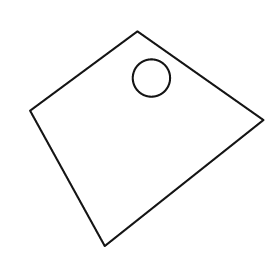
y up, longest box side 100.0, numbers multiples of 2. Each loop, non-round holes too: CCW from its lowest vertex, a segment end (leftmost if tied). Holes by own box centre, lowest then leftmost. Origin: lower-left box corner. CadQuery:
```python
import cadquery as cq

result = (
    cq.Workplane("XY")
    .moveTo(32.0, 0.0)
    .lineTo(100.0, 54.0)
    .lineTo(46.0, 92.0)
    .lineTo(0.0, 58.0)
    .close()
    .moveTo(52.0, 72.0)
    .circle(8.0)
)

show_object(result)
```